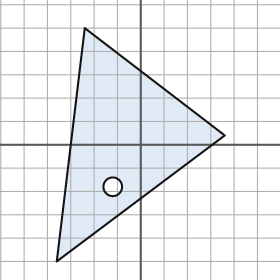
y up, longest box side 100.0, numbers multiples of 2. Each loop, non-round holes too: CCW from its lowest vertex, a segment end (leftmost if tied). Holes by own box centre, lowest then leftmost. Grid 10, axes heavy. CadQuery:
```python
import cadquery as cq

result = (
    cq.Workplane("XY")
    .moveTo(-36.0, -50.0)
    .lineTo(36.0, 4.0)
    .lineTo(-24.0, 50.0)
    .close()
    .moveTo(-12.0, -18.0)
    .circle(4.0)
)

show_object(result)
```